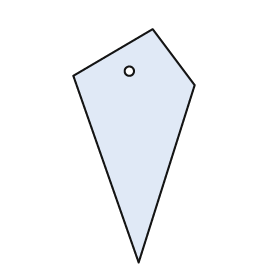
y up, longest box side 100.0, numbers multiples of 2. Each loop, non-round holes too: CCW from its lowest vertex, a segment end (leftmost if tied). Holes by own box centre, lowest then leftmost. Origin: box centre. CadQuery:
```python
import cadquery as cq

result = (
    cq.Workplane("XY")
    .moveTo(2.0, -50.0)
    .lineTo(26.0, 26.0)
    .lineTo(8.0, 50.0)
    .lineTo(-26.0, 30.0)
    .close()
    .moveTo(-2.0, 32.0)
    .circle(2.0)
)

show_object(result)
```